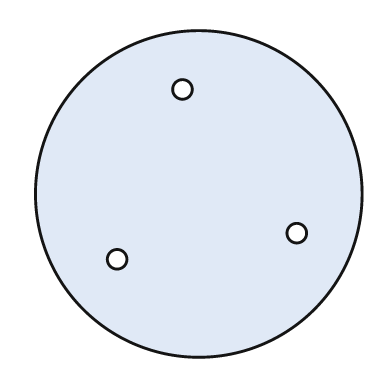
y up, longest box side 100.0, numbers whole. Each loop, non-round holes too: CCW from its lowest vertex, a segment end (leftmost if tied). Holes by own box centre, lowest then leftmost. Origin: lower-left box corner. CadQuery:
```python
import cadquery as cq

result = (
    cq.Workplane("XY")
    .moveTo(50.0, 50.0)
    .circle(50.0)
    .moveTo(25.0, 30.0)
    .circle(3.0)
    .moveTo(80.0, 38.0)
    .circle(3.0)
    .moveTo(45.0, 82.0)
    .circle(3.0)
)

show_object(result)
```